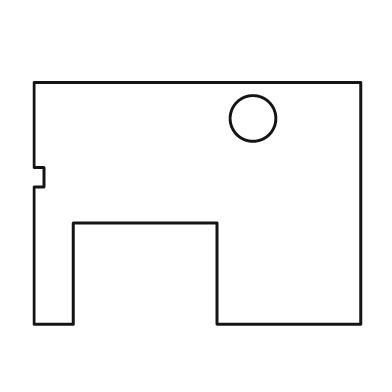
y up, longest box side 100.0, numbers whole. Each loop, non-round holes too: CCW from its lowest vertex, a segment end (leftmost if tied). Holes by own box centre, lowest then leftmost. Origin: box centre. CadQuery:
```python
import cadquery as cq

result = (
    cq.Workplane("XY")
    .moveTo(-50.0, -37.0)
    .lineTo(-38.0, -37.0)
    .lineTo(-38.0, -6.0)
    .lineTo(6.0, -6.0)
    .lineTo(6.0, -37.0)
    .lineTo(50.0, -37.0)
    .lineTo(50.0, 37.0)
    .lineTo(-50.0, 37.0)
    .lineTo(-50.0, 11.0)
    .lineTo(-47.0, 11.0)
    .lineTo(-47.0, 5.0)
    .lineTo(-50.0, 5.0)
    .close()
    .moveTo(17.0, 26.0)
    .circle(7.0)
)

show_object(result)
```